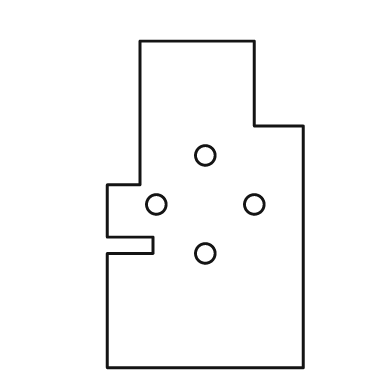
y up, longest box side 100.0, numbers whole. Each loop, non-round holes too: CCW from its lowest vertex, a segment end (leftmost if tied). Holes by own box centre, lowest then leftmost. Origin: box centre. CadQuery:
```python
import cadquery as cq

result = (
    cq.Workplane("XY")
    .moveTo(-30.0, -50.0)
    .lineTo(30.0, -50.0)
    .lineTo(30.0, 24.0)
    .lineTo(15.0, 24.0)
    .lineTo(15.0, 50.0)
    .lineTo(-20.0, 50.0)
    .lineTo(-20.0, 6.0)
    .lineTo(-30.0, 6.0)
    .lineTo(-30.0, -10.0)
    .lineTo(-16.0, -10.0)
    .lineTo(-16.0, -15.0)
    .lineTo(-30.0, -15.0)
    .close()
    .moveTo(0.0, -15.0)
    .circle(3.0)
    .moveTo(-15.0, 0.0)
    .circle(3.0)
    .moveTo(15.0, 0.0)
    .circle(3.0)
    .moveTo(0.0, 15.0)
    .circle(3.0)
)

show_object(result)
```